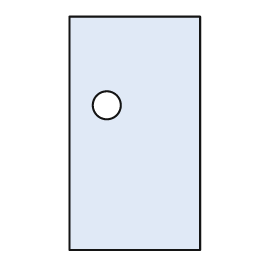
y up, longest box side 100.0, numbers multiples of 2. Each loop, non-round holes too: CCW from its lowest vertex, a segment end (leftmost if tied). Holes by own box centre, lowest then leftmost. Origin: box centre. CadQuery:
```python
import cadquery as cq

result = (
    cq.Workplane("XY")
    .moveTo(-28.0, -50.0)
    .lineTo(28.0, -50.0)
    .lineTo(28.0, 50.0)
    .lineTo(-28.0, 50.0)
    .close()
    .moveTo(-12.0, 12.0)
    .circle(6.0)
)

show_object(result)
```